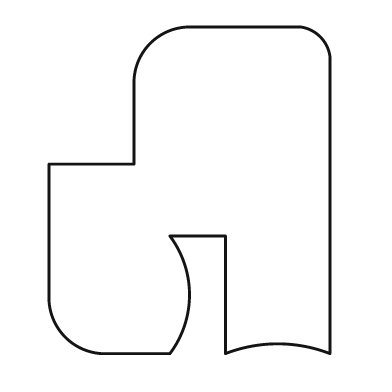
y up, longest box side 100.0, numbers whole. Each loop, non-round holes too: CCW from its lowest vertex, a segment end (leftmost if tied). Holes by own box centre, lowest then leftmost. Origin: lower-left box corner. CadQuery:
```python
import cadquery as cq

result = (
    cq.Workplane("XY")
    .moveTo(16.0, 0.0)
    .lineTo(37.0, 0.0)
    .threePointArc((43.0, 18.0), (37.0, 36.0))
    .lineTo(54.0, 36.0)
    .lineTo(54.0, 0.0)
    .threePointArc((70.0, 3.0), (86.0, 0.0))
    .lineTo(86.0, 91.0)
    .threePointArc((83.0, 97.0), (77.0, 100.0))
    .lineTo(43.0, 100.0)
    .threePointArc((31.0, 95.0), (26.0, 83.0))
    .lineTo(26.0, 58.0)
    .lineTo(0.0, 58.0)
    .lineTo(0.0, 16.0)
    .threePointArc((5.0, 5.0), (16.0, 0.0))
    .close()
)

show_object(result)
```